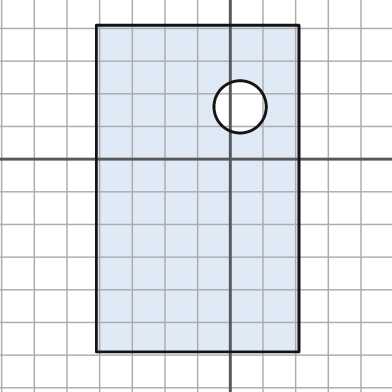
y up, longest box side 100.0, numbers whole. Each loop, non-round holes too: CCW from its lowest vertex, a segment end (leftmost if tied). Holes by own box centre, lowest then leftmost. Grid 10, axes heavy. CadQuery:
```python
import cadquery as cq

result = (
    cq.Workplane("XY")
    .moveTo(-41.0, -59.0)
    .lineTo(21.0, -59.0)
    .lineTo(21.0, 41.0)
    .lineTo(-41.0, 41.0)
    .close()
    .moveTo(3.0, 16.0)
    .circle(8.0)
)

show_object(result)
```